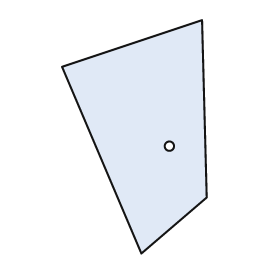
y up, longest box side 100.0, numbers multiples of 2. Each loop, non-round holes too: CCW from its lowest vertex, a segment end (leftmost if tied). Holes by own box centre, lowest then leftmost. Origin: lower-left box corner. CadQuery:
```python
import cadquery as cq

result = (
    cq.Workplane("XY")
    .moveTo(34.0, 0.0)
    .lineTo(62.0, 24.0)
    .lineTo(60.0, 100.0)
    .lineTo(0.0, 80.0)
    .close()
    .moveTo(46.0, 46.0)
    .circle(2.0)
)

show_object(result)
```